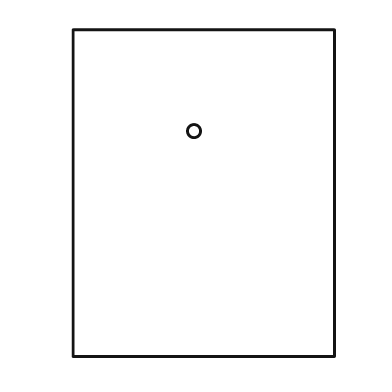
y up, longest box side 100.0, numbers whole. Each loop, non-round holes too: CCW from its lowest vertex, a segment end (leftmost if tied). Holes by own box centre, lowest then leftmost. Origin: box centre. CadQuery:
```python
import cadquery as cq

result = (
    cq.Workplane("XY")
    .moveTo(-40.0, -50.0)
    .lineTo(40.0, -50.0)
    .lineTo(40.0, 50.0)
    .lineTo(-40.0, 50.0)
    .close()
    .moveTo(-3.0, 19.0)
    .circle(2.0)
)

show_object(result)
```